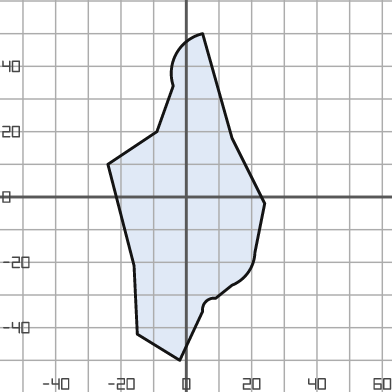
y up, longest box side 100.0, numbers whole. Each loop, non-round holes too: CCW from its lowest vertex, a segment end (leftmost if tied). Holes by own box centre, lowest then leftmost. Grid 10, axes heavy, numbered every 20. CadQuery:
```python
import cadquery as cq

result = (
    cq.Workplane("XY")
    .moveTo(-2.0, -50.0)
    .lineTo(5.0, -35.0)
    .threePointArc((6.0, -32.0), (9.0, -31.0))
    .lineTo(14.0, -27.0)
    .threePointArc((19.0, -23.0), (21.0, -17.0))
    .lineTo(24.0, -2.0)
    .lineTo(14.0, 18.0)
    .lineTo(5.0, 50.0)
    .threePointArc((-3.0, 44.0), (-4.0, 34.0))
    .lineTo(-9.0, 20.0)
    .lineTo(-24.0, 10.0)
    .lineTo(-16.0, -21.0)
    .lineTo(-15.0, -42.0)
    .close()
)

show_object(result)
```